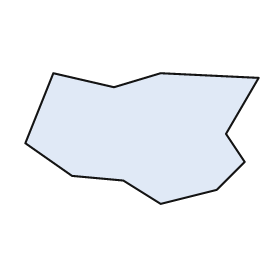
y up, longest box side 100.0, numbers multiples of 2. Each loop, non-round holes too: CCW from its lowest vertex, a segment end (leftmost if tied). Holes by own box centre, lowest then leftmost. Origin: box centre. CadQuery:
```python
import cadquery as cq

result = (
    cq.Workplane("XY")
    .moveTo(8.0, -28.0)
    .lineTo(32.0, -22.0)
    .lineTo(44.0, -10.0)
    .lineTo(36.0, 2.0)
    .lineTo(50.0, 26.0)
    .lineTo(8.0, 28.0)
    .lineTo(-12.0, 22.0)
    .lineTo(-38.0, 28.0)
    .lineTo(-50.0, -2.0)
    .lineTo(-30.0, -16.0)
    .lineTo(-8.0, -18.0)
    .close()
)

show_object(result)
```